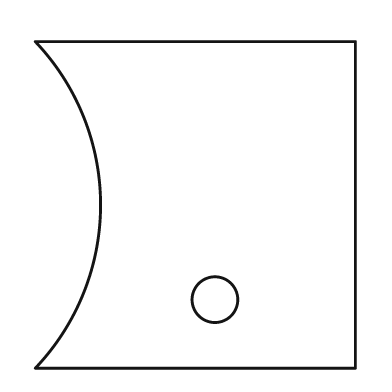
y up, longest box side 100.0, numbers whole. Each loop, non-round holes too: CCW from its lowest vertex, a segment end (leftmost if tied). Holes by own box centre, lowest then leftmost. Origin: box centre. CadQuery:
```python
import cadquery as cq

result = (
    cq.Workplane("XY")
    .moveTo(-49.0, -50.0)
    .lineTo(49.0, -50.0)
    .lineTo(49.0, 50.0)
    .lineTo(-49.0, 50.0)
    .threePointArc((-29.0, 0.0), (-49.0, -50.0))
    .close()
    .moveTo(6.0, -29.0)
    .circle(7.0)
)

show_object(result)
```